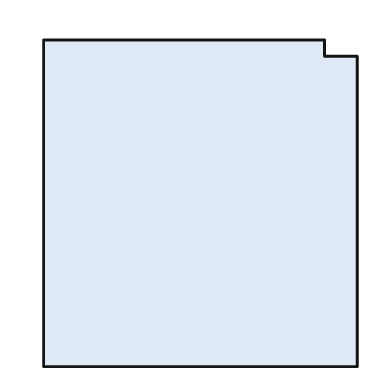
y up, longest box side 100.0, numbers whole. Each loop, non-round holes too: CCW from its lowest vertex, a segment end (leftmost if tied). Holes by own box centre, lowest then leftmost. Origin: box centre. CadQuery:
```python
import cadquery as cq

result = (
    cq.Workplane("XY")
    .moveTo(-48.0, -50.0)
    .lineTo(48.0, -50.0)
    .lineTo(48.0, 45.0)
    .lineTo(38.0, 45.0)
    .lineTo(38.0, 50.0)
    .lineTo(-48.0, 50.0)
    .close()
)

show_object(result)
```